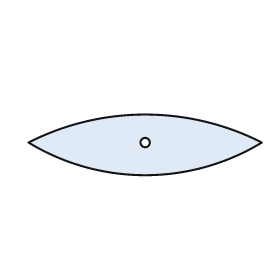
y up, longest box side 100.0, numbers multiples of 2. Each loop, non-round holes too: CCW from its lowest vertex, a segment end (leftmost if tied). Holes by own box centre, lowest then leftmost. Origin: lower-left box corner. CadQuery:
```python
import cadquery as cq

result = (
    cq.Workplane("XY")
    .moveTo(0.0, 14.0)
    .threePointArc((50.0, 0.0), (100.0, 14.0))
    .threePointArc((50.0, 26.0), (0.0, 14.0))
    .close()
    .moveTo(50.0, 14.0)
    .circle(2.0)
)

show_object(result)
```